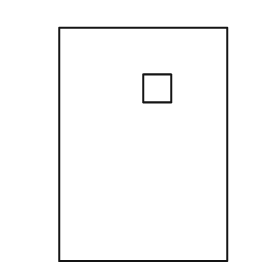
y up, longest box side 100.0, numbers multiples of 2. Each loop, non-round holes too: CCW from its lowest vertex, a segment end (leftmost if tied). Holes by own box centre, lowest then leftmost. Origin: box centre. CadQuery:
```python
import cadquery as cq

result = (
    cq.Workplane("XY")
    .moveTo(-36.0, -50.0)
    .lineTo(36.0, -50.0)
    .lineTo(36.0, 50.0)
    .lineTo(-36.0, 50.0)
    .close()
    .moveTo(0.0, 18.0)
    .lineTo(12.0, 18.0)
    .lineTo(12.0, 30.0)
    .lineTo(0.0, 30.0)
    .close()
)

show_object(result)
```